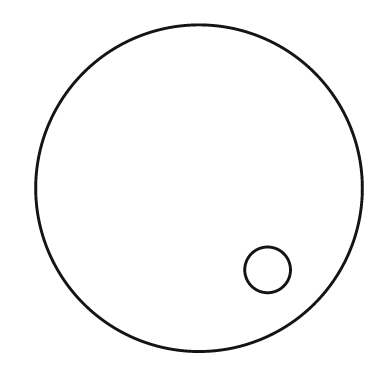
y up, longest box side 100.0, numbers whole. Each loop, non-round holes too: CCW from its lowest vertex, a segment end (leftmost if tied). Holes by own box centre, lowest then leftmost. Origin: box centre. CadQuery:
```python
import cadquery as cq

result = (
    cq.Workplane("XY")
    .moveTo(0.0, 0.0)
    .circle(50.0)
    .moveTo(21.0, -25.0)
    .circle(7.0)
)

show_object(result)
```